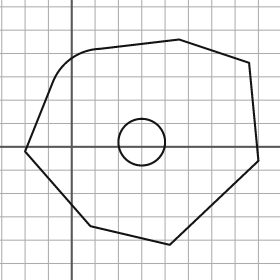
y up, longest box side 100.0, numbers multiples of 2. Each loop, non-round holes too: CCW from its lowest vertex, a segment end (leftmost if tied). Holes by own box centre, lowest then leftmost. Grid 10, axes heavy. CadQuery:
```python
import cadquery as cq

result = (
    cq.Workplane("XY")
    .moveTo(42.0, -42.0)
    .lineTo(80.0, -6.0)
    .lineTo(76.0, 36.0)
    .lineTo(46.0, 46.0)
    .lineTo(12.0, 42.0)
    .threePointArc((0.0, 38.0), (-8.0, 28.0))
    .lineTo(-20.0, -2.0)
    .lineTo(8.0, -34.0)
    .close()
    .moveTo(30.0, 2.0)
    .circle(10.0)
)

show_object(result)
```